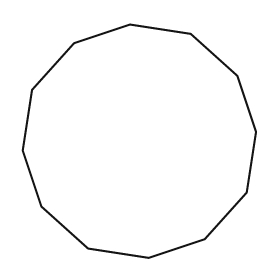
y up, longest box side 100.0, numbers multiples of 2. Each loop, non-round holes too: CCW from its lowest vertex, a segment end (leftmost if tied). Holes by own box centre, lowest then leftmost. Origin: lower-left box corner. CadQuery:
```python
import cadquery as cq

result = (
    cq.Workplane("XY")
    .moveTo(54.0, 0.0)
    .lineTo(78.0, 8.0)
    .lineTo(96.0, 28.0)
    .lineTo(100.0, 54.0)
    .lineTo(92.0, 78.0)
    .lineTo(72.0, 96.0)
    .lineTo(46.0, 100.0)
    .lineTo(22.0, 92.0)
    .lineTo(4.0, 72.0)
    .lineTo(0.0, 46.0)
    .lineTo(8.0, 22.0)
    .lineTo(28.0, 4.0)
    .close()
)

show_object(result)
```